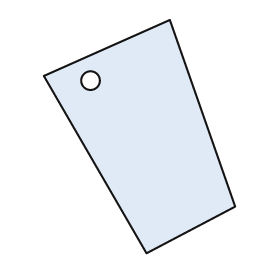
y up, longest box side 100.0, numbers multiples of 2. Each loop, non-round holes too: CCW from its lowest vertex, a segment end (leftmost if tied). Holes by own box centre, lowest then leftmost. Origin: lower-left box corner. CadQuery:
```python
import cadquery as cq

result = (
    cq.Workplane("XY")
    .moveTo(44.0, 0.0)
    .lineTo(82.0, 20.0)
    .lineTo(54.0, 100.0)
    .lineTo(0.0, 76.0)
    .close()
    .moveTo(20.0, 74.0)
    .circle(4.0)
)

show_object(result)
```